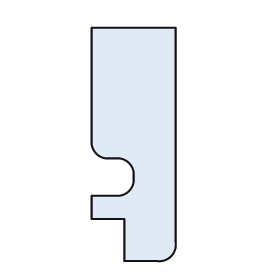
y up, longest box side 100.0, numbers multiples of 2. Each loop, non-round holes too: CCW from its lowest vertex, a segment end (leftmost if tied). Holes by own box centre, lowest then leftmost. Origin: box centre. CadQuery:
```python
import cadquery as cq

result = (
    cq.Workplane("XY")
    .moveTo(-4.0, -50.0)
    .lineTo(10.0, -50.0)
    .threePointArc((16.0, -48.0), (18.0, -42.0))
    .lineTo(18.0, 50.0)
    .lineTo(-18.0, 50.0)
    .lineTo(-18.0, 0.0)
    .threePointArc((-16.0, -4.0), (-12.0, -6.0))
    .lineTo(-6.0, -6.0)
    .threePointArc((-2.0, -8.0), (0.0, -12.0))
    .lineTo(0.0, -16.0)
    .threePointArc((-2.0, -20.0), (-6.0, -22.0))
    .lineTo(-18.0, -22.0)
    .lineTo(-18.0, -32.0)
    .lineTo(-4.0, -32.0)
    .close()
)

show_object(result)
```